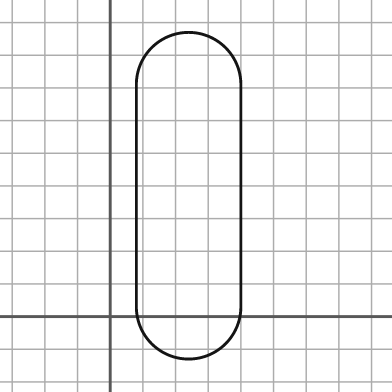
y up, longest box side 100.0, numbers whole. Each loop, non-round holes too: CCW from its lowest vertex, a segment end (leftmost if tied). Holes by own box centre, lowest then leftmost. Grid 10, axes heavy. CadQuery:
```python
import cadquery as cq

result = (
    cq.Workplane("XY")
    .moveTo(8.0, 3.0)
    .threePointArc((24.0, -13.0), (40.0, 3.0))
    .lineTo(40.0, 71.0)
    .threePointArc((24.0, 87.0), (8.0, 71.0))
    .close()
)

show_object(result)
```